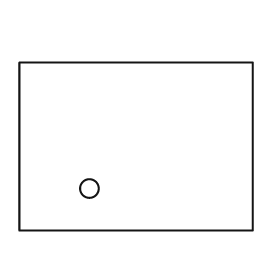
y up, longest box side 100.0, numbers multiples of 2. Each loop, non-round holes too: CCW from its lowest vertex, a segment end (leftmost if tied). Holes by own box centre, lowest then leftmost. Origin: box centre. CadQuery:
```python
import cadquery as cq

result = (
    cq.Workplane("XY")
    .moveTo(-50.0, -36.0)
    .lineTo(50.0, -36.0)
    .lineTo(50.0, 36.0)
    .lineTo(-50.0, 36.0)
    .close()
    .moveTo(-20.0, -18.0)
    .circle(4.0)
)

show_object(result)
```